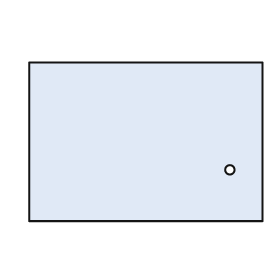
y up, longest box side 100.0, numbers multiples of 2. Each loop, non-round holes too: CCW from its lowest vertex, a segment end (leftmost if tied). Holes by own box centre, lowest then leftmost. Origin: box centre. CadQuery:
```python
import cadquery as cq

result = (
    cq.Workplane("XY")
    .moveTo(-50.0, -34.0)
    .lineTo(50.0, -34.0)
    .lineTo(50.0, 34.0)
    .lineTo(-50.0, 34.0)
    .close()
    .moveTo(36.0, -12.0)
    .circle(2.0)
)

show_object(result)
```